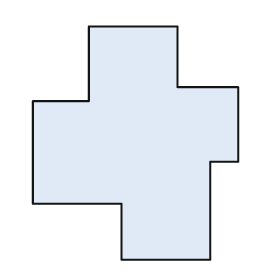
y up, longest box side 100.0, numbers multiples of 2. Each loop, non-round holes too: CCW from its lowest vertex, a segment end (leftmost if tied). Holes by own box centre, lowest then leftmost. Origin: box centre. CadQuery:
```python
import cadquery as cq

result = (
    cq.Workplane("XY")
    .moveTo(-6.0, -50.0)
    .lineTo(32.0, -50.0)
    .lineTo(32.0, -8.0)
    .lineTo(44.0, -8.0)
    .lineTo(44.0, 24.0)
    .lineTo(18.0, 24.0)
    .lineTo(18.0, 50.0)
    .lineTo(-20.0, 50.0)
    .lineTo(-20.0, 18.0)
    .lineTo(-44.0, 18.0)
    .lineTo(-44.0, -26.0)
    .lineTo(-6.0, -26.0)
    .close()
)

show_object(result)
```